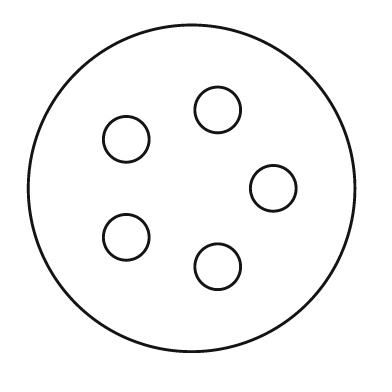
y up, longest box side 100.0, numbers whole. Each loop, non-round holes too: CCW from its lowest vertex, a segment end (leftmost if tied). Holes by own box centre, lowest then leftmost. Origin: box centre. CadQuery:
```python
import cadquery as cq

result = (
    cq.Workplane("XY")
    .moveTo(0.0, 0.0)
    .circle(50.0)
    .moveTo(8.0, -24.0)
    .circle(7.0)
    .moveTo(-20.0, -15.0)
    .circle(7.0)
    .moveTo(25.0, 0.0)
    .circle(7.0)
    .moveTo(-20.0, 15.0)
    .circle(7.0)
    .moveTo(8.0, 24.0)
    .circle(7.0)
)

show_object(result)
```